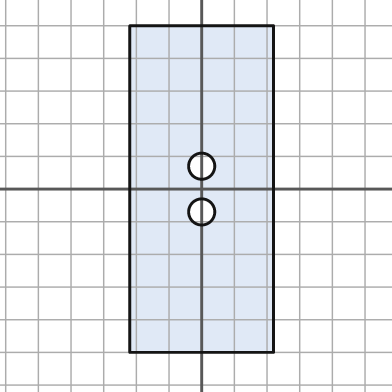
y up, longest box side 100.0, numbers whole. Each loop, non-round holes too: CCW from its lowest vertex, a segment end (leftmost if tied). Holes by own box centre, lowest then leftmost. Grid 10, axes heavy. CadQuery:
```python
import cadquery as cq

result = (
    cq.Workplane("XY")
    .moveTo(-22.0, -50.0)
    .lineTo(22.0, -50.0)
    .lineTo(22.0, 50.0)
    .lineTo(-22.0, 50.0)
    .close()
    .moveTo(0.0, -7.0)
    .circle(4.0)
    .moveTo(0.0, 7.0)
    .circle(4.0)
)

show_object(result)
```